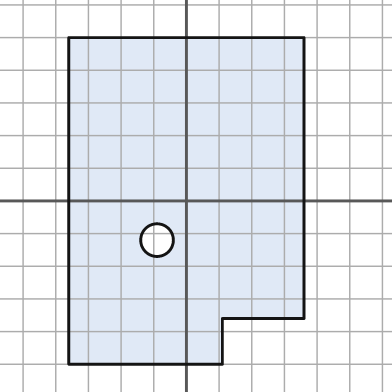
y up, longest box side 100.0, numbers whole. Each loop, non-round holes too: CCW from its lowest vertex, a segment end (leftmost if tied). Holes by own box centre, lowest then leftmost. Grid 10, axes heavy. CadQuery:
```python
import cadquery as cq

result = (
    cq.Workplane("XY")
    .moveTo(-36.0, -50.0)
    .lineTo(11.0, -50.0)
    .lineTo(11.0, -36.0)
    .lineTo(36.0, -36.0)
    .lineTo(36.0, 50.0)
    .lineTo(-36.0, 50.0)
    .close()
    .moveTo(-9.0, -12.0)
    .circle(5.0)
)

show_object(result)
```